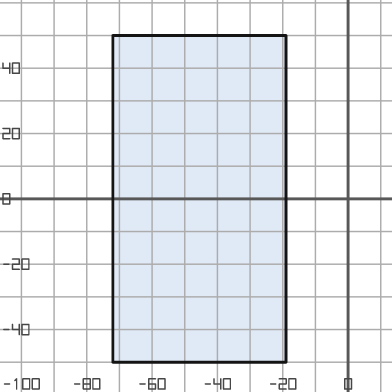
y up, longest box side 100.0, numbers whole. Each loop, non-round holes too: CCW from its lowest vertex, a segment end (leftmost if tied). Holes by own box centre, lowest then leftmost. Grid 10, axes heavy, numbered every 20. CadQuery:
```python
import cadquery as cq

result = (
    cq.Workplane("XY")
    .moveTo(-72.0, -50.0)
    .lineTo(-19.0, -50.0)
    .lineTo(-19.0, 50.0)
    .lineTo(-72.0, 50.0)
    .close()
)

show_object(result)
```